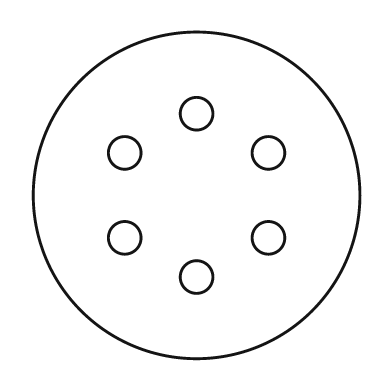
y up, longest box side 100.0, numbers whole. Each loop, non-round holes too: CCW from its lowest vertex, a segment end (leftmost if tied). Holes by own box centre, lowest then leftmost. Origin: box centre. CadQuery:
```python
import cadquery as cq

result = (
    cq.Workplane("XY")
    .moveTo(0.0, 0.0)
    .circle(50.0)
    .moveTo(0.0, -25.0)
    .circle(5.0)
    .moveTo(-22.0, -13.0)
    .circle(5.0)
    .moveTo(22.0, -13.0)
    .circle(5.0)
    .moveTo(-22.0, 13.0)
    .circle(5.0)
    .moveTo(22.0, 13.0)
    .circle(5.0)
    .moveTo(0.0, 25.0)
    .circle(5.0)
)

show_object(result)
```